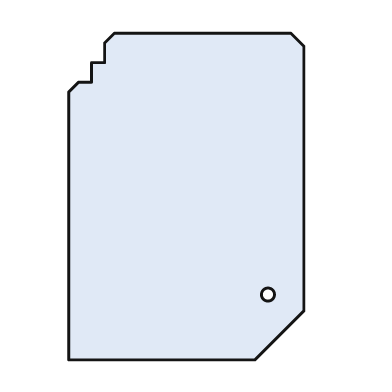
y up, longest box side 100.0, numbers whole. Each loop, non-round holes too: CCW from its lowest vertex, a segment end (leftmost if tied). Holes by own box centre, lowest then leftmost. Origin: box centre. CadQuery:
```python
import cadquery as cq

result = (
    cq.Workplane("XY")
    .moveTo(-36.0, -50.0)
    .lineTo(21.0, -50.0)
    .lineTo(36.0, -35.0)
    .lineTo(36.0, 46.0)
    .lineTo(32.0, 50.0)
    .lineTo(-22.0, 50.0)
    .lineTo(-25.0, 47.0)
    .lineTo(-25.0, 41.0)
    .lineTo(-29.0, 41.0)
    .lineTo(-29.0, 35.0)
    .lineTo(-33.0, 35.0)
    .lineTo(-36.0, 32.0)
    .close()
    .moveTo(25.0, -30.0)
    .circle(2.0)
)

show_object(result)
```